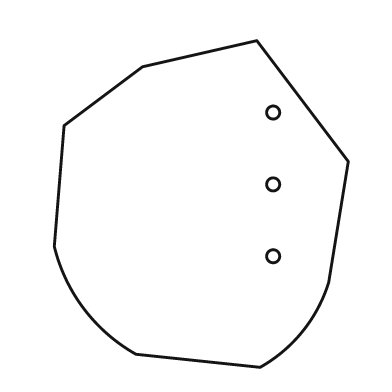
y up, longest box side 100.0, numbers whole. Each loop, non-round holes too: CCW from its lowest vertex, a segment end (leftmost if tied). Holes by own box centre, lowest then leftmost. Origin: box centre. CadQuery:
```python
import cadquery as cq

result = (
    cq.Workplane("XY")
    .moveTo(18.0, -50.0)
    .threePointArc((31.0, -39.0), (39.0, -24.0))
    .lineTo(45.0, 13.0)
    .lineTo(17.0, 50.0)
    .lineTo(-18.0, 42.0)
    .lineTo(-42.0, 24.0)
    .lineTo(-45.0, -13.0)
    .threePointArc((-36.0, -32.0), (-20.0, -46.0))
    .close()
    .moveTo(22.0, -16.0)
    .circle(2.0)
    .moveTo(22.0, 6.0)
    .circle(2.0)
    .moveTo(22.0, 28.0)
    .circle(2.0)
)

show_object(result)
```